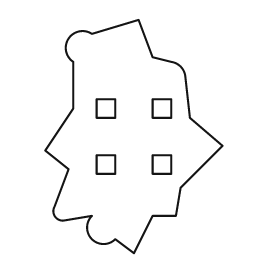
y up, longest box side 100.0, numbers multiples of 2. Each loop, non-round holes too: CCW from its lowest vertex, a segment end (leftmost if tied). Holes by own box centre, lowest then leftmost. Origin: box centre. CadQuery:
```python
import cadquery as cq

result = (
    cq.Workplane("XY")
    .moveTo(0.0, -50.0)
    .lineTo(8.0, -34.0)
    .lineTo(18.0, -34.0)
    .lineTo(20.0, -22.0)
    .lineTo(38.0, -4.0)
    .lineTo(24.0, 8.0)
    .lineTo(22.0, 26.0)
    .threePointArc((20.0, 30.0), (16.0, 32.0))
    .lineTo(8.0, 34.0)
    .lineTo(2.0, 50.0)
    .lineTo(-18.0, 44.0)
    .threePointArc((-28.0, 42.0), (-26.0, 32.0))
    .lineTo(-26.0, 12.0)
    .lineTo(-38.0, -6.0)
    .lineTo(-28.0, -14.0)
    .lineTo(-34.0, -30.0)
    .threePointArc((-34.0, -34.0), (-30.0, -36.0))
    .lineTo(-18.0, -34.0)
    .threePointArc((-18.0, -44.0), (-8.0, -44.0))
    .close()
    .moveTo(-16.0, -16.0)
    .lineTo(-8.0, -16.0)
    .lineTo(-8.0, -8.0)
    .lineTo(-16.0, -8.0)
    .close()
    .moveTo(8.0, -16.0)
    .lineTo(16.0, -16.0)
    .lineTo(16.0, -8.0)
    .lineTo(8.0, -8.0)
    .close()
    .moveTo(-16.0, 8.0)
    .lineTo(-8.0, 8.0)
    .lineTo(-8.0, 16.0)
    .lineTo(-16.0, 16.0)
    .close()
    .moveTo(8.0, 8.0)
    .lineTo(16.0, 8.0)
    .lineTo(16.0, 16.0)
    .lineTo(8.0, 16.0)
    .close()
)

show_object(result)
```